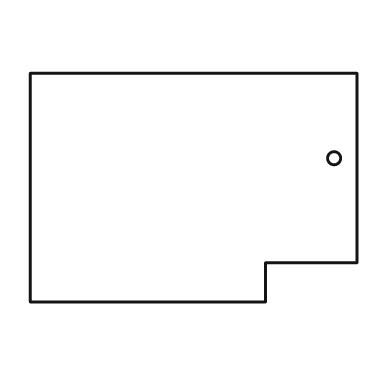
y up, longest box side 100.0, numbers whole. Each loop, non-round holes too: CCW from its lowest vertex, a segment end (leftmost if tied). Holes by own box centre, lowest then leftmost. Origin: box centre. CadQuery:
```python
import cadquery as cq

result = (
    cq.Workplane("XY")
    .moveTo(-50.0, -35.0)
    .lineTo(22.0, -35.0)
    .lineTo(22.0, -23.0)
    .lineTo(50.0, -23.0)
    .lineTo(50.0, 35.0)
    .lineTo(-50.0, 35.0)
    .close()
    .moveTo(43.0, 9.0)
    .circle(2.0)
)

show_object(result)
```